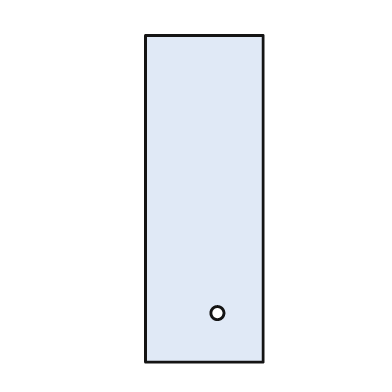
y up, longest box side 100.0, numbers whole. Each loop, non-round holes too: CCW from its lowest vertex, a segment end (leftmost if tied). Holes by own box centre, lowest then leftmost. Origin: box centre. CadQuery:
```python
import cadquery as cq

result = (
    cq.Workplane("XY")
    .moveTo(-18.0, -50.0)
    .lineTo(18.0, -50.0)
    .lineTo(18.0, 50.0)
    .lineTo(-18.0, 50.0)
    .close()
    .moveTo(4.0, -35.0)
    .circle(2.0)
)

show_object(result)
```